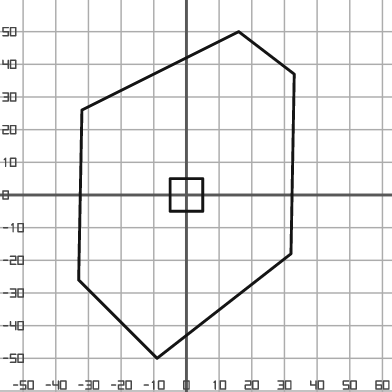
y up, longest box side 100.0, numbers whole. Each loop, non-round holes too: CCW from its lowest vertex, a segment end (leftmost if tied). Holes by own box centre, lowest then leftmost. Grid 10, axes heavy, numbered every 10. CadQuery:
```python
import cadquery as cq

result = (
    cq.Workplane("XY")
    .moveTo(-9.0, -50.0)
    .lineTo(32.0, -18.0)
    .lineTo(33.0, 37.0)
    .lineTo(16.0, 50.0)
    .lineTo(-32.0, 26.0)
    .lineTo(-33.0, -26.0)
    .close()
    .moveTo(-5.0, -5.0)
    .lineTo(5.0, -5.0)
    .lineTo(5.0, 5.0)
    .lineTo(-5.0, 5.0)
    .close()
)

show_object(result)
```